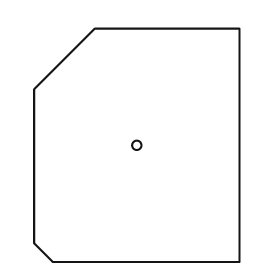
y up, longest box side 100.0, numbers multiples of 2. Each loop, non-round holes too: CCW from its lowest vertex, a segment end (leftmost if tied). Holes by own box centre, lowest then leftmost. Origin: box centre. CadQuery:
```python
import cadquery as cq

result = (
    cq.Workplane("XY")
    .moveTo(-36.0, -50.0)
    .lineTo(44.0, -50.0)
    .lineTo(44.0, 50.0)
    .lineTo(-18.0, 50.0)
    .lineTo(-44.0, 24.0)
    .lineTo(-44.0, -42.0)
    .close()
    .moveTo(0.0, 0.0)
    .circle(2.0)
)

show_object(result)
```